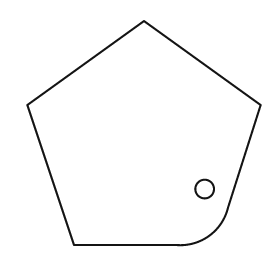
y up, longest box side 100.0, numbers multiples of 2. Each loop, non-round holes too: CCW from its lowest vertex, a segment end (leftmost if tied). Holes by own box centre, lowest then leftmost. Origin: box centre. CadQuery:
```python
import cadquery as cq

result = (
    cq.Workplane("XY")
    .moveTo(-30.0, -48.0)
    .lineTo(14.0, -48.0)
    .threePointArc((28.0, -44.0), (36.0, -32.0))
    .lineTo(50.0, 12.0)
    .lineTo(0.0, 48.0)
    .lineTo(-50.0, 12.0)
    .close()
    .moveTo(26.0, -24.0)
    .circle(4.0)
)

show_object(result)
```